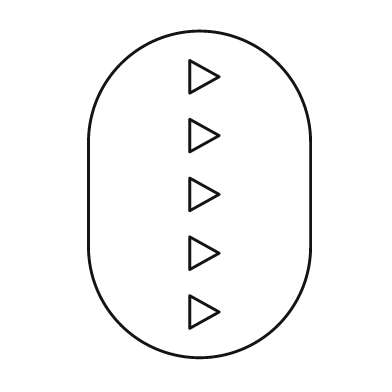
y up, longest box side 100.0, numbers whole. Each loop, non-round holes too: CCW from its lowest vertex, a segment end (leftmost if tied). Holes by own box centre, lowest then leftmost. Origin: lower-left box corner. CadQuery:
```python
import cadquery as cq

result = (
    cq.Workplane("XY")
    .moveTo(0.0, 34.0)
    .threePointArc((34.0, 0.0), (68.0, 34.0))
    .lineTo(68.0, 66.0)
    .threePointArc((34.0, 100.0), (0.0, 66.0))
    .close()
    .moveTo(31.0, 9.0)
    .lineTo(40.0, 14.0)
    .lineTo(31.0, 19.0)
    .close()
    .moveTo(31.0, 27.0)
    .lineTo(40.0, 32.0)
    .lineTo(31.0, 37.0)
    .close()
    .moveTo(31.0, 45.0)
    .lineTo(40.0, 50.0)
    .lineTo(31.0, 55.0)
    .close()
    .moveTo(31.0, 63.0)
    .lineTo(40.0, 68.0)
    .lineTo(31.0, 73.0)
    .close()
    .moveTo(31.0, 81.0)
    .lineTo(40.0, 86.0)
    .lineTo(31.0, 91.0)
    .close()
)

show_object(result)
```